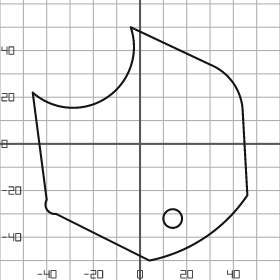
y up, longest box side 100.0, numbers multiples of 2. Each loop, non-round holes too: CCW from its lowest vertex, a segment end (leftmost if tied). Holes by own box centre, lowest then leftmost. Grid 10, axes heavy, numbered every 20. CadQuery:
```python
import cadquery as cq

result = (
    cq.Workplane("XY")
    .moveTo(4.0, -50.0)
    .threePointArc((28.0, -40.0), (46.0, -22.0))
    .lineTo(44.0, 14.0)
    .threePointArc((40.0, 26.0), (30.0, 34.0))
    .lineTo(-4.0, 50.0)
    .threePointArc((-14.0, 20.0), (-46.0, 22.0))
    .lineTo(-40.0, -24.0)
    .threePointArc((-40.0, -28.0), (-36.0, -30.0))
    .close()
    .moveTo(14.0, -32.0)
    .circle(4.0)
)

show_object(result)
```